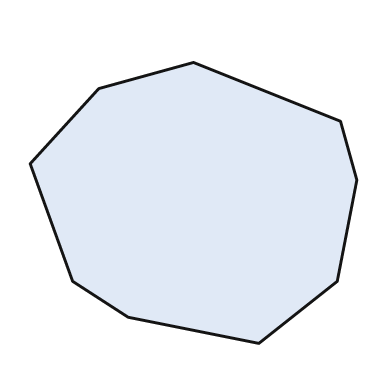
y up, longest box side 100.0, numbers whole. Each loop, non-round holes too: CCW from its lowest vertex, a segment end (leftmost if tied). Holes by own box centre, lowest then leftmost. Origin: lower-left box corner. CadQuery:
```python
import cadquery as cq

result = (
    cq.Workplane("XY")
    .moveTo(70.0, 0.0)
    .lineTo(94.0, 19.0)
    .lineTo(100.0, 50.0)
    .lineTo(95.0, 68.0)
    .lineTo(50.0, 86.0)
    .lineTo(21.0, 78.0)
    .lineTo(0.0, 55.0)
    .lineTo(13.0, 19.0)
    .lineTo(30.0, 8.0)
    .close()
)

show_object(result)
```